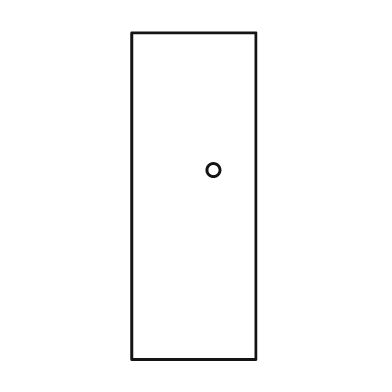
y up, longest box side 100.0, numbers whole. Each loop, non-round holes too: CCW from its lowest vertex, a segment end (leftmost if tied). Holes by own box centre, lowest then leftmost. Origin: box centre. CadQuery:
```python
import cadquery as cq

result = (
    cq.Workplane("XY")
    .moveTo(-19.0, -50.0)
    .lineTo(19.0, -50.0)
    .lineTo(19.0, 50.0)
    .lineTo(-19.0, 50.0)
    .close()
    .moveTo(6.0, 8.0)
    .circle(2.0)
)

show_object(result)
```